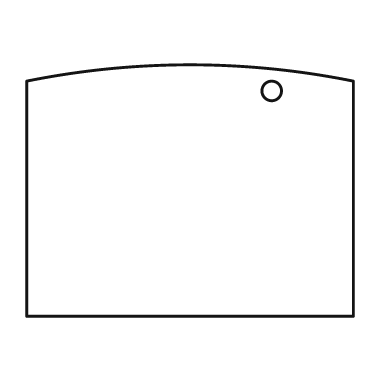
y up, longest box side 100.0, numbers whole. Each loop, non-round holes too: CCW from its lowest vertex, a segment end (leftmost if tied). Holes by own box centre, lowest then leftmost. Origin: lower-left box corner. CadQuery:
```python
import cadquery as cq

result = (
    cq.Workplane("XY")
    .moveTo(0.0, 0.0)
    .lineTo(100.0, 0.0)
    .lineTo(100.0, 72.0)
    .threePointArc((50.0, 77.0), (0.0, 72.0))
    .close()
    .moveTo(75.0, 69.0)
    .circle(3.0)
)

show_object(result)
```